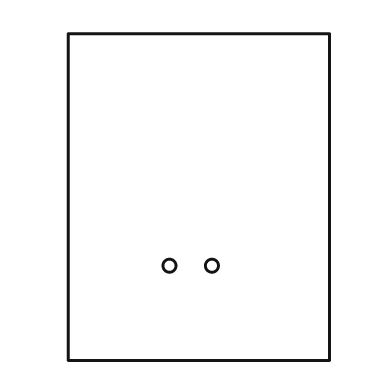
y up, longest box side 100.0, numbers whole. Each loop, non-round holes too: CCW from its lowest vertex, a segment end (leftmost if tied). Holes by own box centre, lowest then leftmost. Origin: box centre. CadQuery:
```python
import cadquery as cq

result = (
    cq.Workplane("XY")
    .moveTo(-40.0, -50.0)
    .lineTo(40.0, -50.0)
    .lineTo(40.0, 50.0)
    .lineTo(-40.0, 50.0)
    .close()
    .moveTo(-9.0, -21.0)
    .circle(2.0)
    .moveTo(4.0, -21.0)
    .circle(2.0)
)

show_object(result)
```